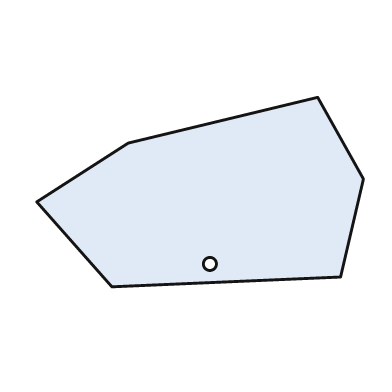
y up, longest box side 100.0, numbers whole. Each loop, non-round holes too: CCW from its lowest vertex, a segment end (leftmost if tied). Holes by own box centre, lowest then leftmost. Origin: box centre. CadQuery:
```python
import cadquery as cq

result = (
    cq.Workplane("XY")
    .moveTo(-27.0, -29.0)
    .lineTo(43.0, -26.0)
    .lineTo(50.0, 4.0)
    .lineTo(36.0, 29.0)
    .lineTo(-22.0, 15.0)
    .lineTo(-50.0, -3.0)
    .close()
    .moveTo(3.0, -22.0)
    .circle(2.0)
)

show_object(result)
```